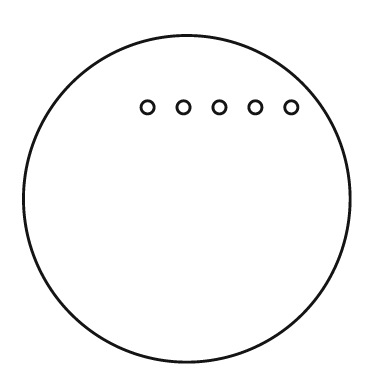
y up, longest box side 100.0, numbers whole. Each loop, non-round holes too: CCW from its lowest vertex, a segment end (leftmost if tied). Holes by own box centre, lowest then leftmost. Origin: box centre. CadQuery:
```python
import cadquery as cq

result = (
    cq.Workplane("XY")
    .moveTo(0.0, 0.0)
    .circle(50.0)
    .moveTo(-12.0, 28.0)
    .circle(2.0)
    .moveTo(-1.0, 28.0)
    .circle(2.0)
    .moveTo(10.0, 28.0)
    .circle(2.0)
    .moveTo(21.0, 28.0)
    .circle(2.0)
    .moveTo(32.0, 28.0)
    .circle(2.0)
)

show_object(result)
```